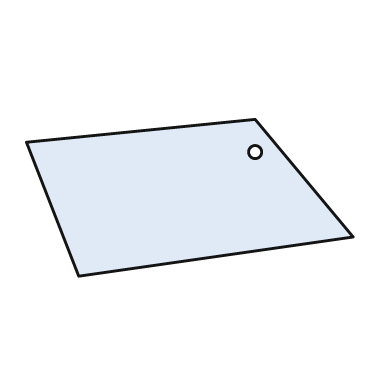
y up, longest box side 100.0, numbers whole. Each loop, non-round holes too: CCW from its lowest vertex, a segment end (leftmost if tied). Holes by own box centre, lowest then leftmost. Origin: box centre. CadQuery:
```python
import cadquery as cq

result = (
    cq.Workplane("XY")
    .moveTo(-34.0, -24.0)
    .lineTo(50.0, -12.0)
    .lineTo(20.0, 24.0)
    .lineTo(-50.0, 17.0)
    .close()
    .moveTo(20.0, 14.0)
    .circle(2.0)
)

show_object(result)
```